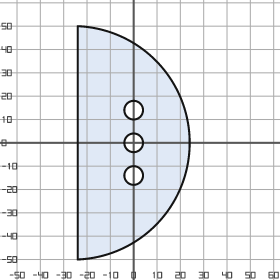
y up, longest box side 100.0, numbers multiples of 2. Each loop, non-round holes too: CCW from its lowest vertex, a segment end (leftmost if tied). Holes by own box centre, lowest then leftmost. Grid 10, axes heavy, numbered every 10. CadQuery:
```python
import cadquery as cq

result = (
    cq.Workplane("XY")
    .moveTo(-24.0, -50.0)
    .threePointArc((24.0, 0.0), (-24.0, 50.0))
    .close()
    .moveTo(0.0, -14.0)
    .circle(4.0)
    .moveTo(0.0, 0.0)
    .circle(4.0)
    .moveTo(0.0, 14.0)
    .circle(4.0)
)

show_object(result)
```